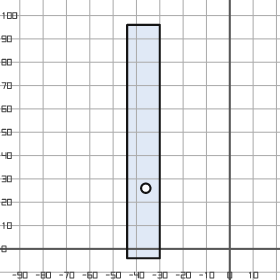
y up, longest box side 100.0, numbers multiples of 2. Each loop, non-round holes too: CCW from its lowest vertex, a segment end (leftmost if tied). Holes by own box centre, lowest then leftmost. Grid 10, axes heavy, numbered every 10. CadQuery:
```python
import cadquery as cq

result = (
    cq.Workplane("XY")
    .moveTo(-44.0, -4.0)
    .lineTo(-30.0, -4.0)
    .lineTo(-30.0, 96.0)
    .lineTo(-44.0, 96.0)
    .close()
    .moveTo(-36.0, 26.0)
    .circle(2.0)
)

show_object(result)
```